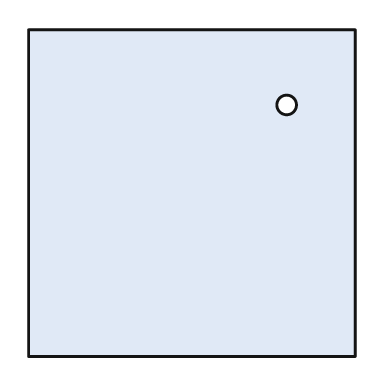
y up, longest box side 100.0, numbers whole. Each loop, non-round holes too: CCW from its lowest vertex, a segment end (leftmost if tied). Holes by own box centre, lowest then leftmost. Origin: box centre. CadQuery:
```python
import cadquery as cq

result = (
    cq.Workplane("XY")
    .moveTo(-50.0, -50.0)
    .lineTo(50.0, -50.0)
    .lineTo(50.0, 50.0)
    .lineTo(-50.0, 50.0)
    .close()
    .moveTo(29.0, 27.0)
    .circle(3.0)
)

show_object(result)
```